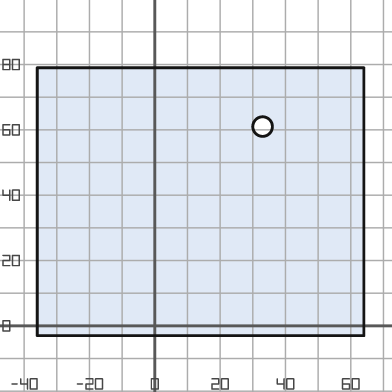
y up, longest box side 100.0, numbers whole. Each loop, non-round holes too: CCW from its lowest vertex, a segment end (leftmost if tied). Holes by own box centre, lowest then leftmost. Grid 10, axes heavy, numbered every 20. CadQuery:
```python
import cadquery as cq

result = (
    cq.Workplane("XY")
    .moveTo(-36.0, -3.0)
    .lineTo(64.0, -3.0)
    .lineTo(64.0, 79.0)
    .lineTo(-36.0, 79.0)
    .close()
    .moveTo(33.0, 61.0)
    .circle(3.0)
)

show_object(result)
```